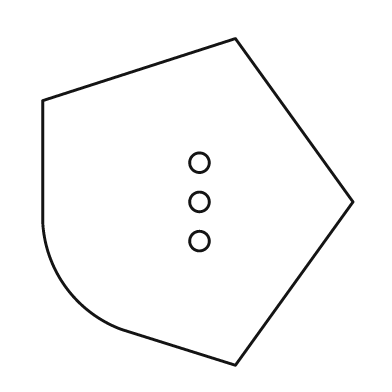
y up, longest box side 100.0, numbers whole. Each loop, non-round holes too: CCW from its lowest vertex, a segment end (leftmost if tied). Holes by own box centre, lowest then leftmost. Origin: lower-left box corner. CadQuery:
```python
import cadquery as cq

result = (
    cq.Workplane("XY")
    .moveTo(59.0, 0.0)
    .lineTo(95.0, 50.0)
    .lineTo(59.0, 100.0)
    .lineTo(0.0, 81.0)
    .lineTo(0.0, 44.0)
    .threePointArc((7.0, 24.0), (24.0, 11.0))
    .close()
    .moveTo(48.0, 38.0)
    .circle(3.0)
    .moveTo(48.0, 50.0)
    .circle(3.0)
    .moveTo(48.0, 62.0)
    .circle(3.0)
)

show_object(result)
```